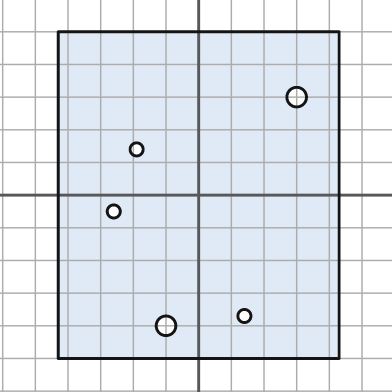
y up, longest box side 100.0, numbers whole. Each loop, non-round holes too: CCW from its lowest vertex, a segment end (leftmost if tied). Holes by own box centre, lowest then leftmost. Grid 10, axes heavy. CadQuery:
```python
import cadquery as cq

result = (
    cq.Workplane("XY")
    .moveTo(-43.0, -50.0)
    .lineTo(43.0, -50.0)
    .lineTo(43.0, 50.0)
    .lineTo(-43.0, 50.0)
    .close()
    .moveTo(-10.0, -40.0)
    .circle(3.0)
    .moveTo(14.0, -37.0)
    .circle(2.0)
    .moveTo(-26.0, -5.0)
    .circle(2.0)
    .moveTo(-19.0, 14.0)
    .circle(2.0)
    .moveTo(30.0, 30.0)
    .circle(3.0)
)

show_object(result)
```